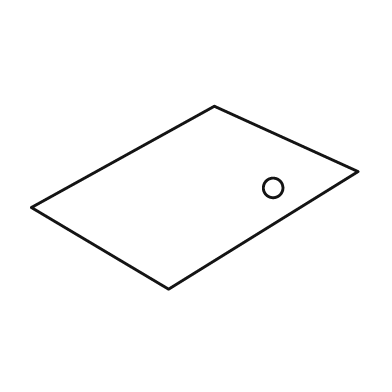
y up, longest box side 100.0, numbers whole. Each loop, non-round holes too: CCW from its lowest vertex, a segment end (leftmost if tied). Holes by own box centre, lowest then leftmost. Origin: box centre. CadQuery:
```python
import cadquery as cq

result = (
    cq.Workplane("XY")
    .moveTo(-8.0, -28.0)
    .lineTo(50.0, 8.0)
    .lineTo(6.0, 28.0)
    .lineTo(-50.0, -3.0)
    .close()
    .moveTo(24.0, 3.0)
    .circle(3.0)
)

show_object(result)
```